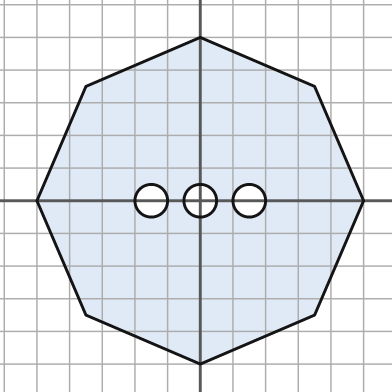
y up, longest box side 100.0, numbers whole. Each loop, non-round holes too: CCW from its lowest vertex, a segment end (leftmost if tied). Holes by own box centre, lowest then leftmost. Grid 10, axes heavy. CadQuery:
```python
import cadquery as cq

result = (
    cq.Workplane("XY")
    .moveTo(0.0, -50.0)
    .lineTo(35.0, -35.0)
    .lineTo(50.0, 0.0)
    .lineTo(35.0, 35.0)
    .lineTo(0.0, 50.0)
    .lineTo(-35.0, 35.0)
    .lineTo(-50.0, 0.0)
    .lineTo(-35.0, -35.0)
    .close()
    .moveTo(-15.0, 0.0)
    .circle(5.0)
    .moveTo(0.0, 0.0)
    .circle(5.0)
    .moveTo(15.0, 0.0)
    .circle(5.0)
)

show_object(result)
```